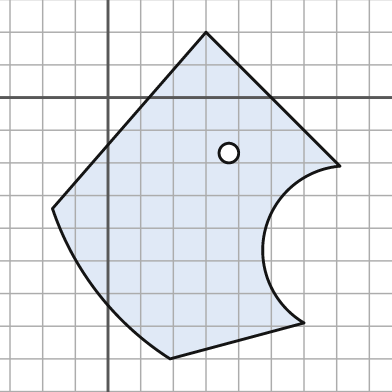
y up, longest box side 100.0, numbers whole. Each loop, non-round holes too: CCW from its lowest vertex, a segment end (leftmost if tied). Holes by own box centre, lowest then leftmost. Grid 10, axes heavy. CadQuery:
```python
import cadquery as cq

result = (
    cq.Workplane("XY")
    .moveTo(19.0, -80.0)
    .lineTo(60.0, -69.0)
    .threePointArc((48.0, -41.0), (71.0, -21.0))
    .lineTo(30.0, 20.0)
    .lineTo(-17.0, -34.0)
    .threePointArc((-3.0, -60.0), (19.0, -80.0))
    .close()
    .moveTo(37.0, -17.0)
    .circle(3.0)
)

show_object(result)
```